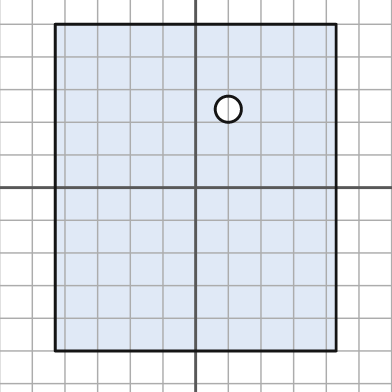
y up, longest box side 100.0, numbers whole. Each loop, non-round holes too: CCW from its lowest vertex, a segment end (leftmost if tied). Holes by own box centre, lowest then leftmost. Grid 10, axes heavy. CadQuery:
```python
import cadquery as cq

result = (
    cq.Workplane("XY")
    .moveTo(-43.0, -50.0)
    .lineTo(43.0, -50.0)
    .lineTo(43.0, 50.0)
    .lineTo(-43.0, 50.0)
    .close()
    .moveTo(10.0, 24.0)
    .circle(4.0)
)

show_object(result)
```